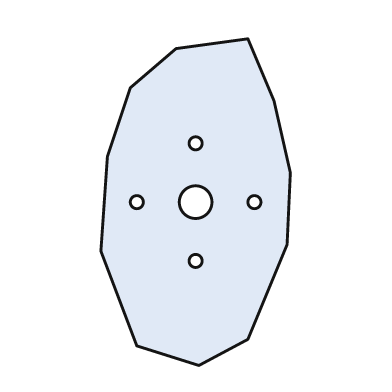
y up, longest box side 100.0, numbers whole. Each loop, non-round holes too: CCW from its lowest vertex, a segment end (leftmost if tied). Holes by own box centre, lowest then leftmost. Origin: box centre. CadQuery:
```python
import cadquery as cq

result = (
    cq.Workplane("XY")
    .moveTo(1.0, -50.0)
    .lineTo(16.0, -42.0)
    .lineTo(28.0, -13.0)
    .lineTo(29.0, 9.0)
    .lineTo(24.0, 31.0)
    .lineTo(16.0, 50.0)
    .lineTo(-6.0, 47.0)
    .lineTo(-20.0, 35.0)
    .lineTo(-27.0, 14.0)
    .lineTo(-29.0, -15.0)
    .lineTo(-18.0, -44.0)
    .close()
    .moveTo(0.0, -18.0)
    .circle(2.0)
    .moveTo(-18.0, 0.0)
    .circle(2.0)
    .moveTo(0.0, 0.0)
    .circle(5.0)
    .moveTo(18.0, 0.0)
    .circle(2.0)
    .moveTo(0.0, 18.0)
    .circle(2.0)
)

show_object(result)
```